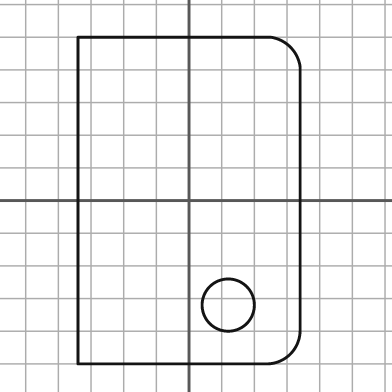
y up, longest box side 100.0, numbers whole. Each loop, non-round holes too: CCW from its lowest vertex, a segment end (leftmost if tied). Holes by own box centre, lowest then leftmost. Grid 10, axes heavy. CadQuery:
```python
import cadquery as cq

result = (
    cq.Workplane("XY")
    .moveTo(-34.0, -50.0)
    .lineTo(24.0, -50.0)
    .threePointArc((31.0, -47.0), (34.0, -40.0))
    .lineTo(34.0, 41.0)
    .threePointArc((31.0, 47.0), (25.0, 50.0))
    .lineTo(-34.0, 50.0)
    .close()
    .moveTo(12.0, -32.0)
    .circle(8.0)
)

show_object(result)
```